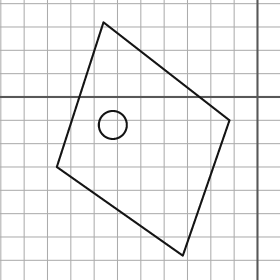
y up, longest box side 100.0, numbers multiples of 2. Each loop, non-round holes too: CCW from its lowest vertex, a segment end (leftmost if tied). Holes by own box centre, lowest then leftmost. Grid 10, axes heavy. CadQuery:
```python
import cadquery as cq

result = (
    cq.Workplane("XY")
    .moveTo(-32.0, -68.0)
    .lineTo(-12.0, -10.0)
    .lineTo(-66.0, 32.0)
    .lineTo(-86.0, -30.0)
    .close()
    .moveTo(-62.0, -12.0)
    .circle(6.0)
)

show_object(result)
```